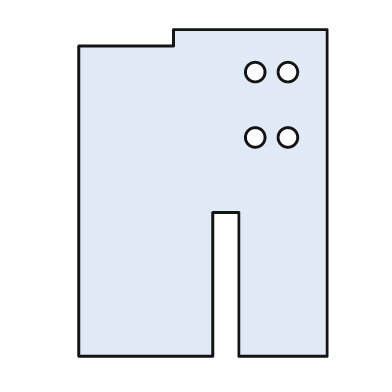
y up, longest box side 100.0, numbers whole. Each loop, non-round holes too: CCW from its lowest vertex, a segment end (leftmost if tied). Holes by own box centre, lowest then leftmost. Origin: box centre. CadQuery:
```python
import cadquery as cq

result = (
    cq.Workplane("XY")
    .moveTo(-38.0, -50.0)
    .lineTo(3.0, -50.0)
    .lineTo(3.0, -6.0)
    .lineTo(11.0, -6.0)
    .lineTo(11.0, -50.0)
    .lineTo(38.0, -50.0)
    .lineTo(38.0, 50.0)
    .lineTo(-9.0, 50.0)
    .lineTo(-9.0, 45.0)
    .lineTo(-38.0, 45.0)
    .close()
    .moveTo(16.0, 17.0)
    .circle(3.0)
    .moveTo(26.0, 17.0)
    .circle(3.0)
    .moveTo(16.0, 37.0)
    .circle(3.0)
    .moveTo(26.0, 37.0)
    .circle(3.0)
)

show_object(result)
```